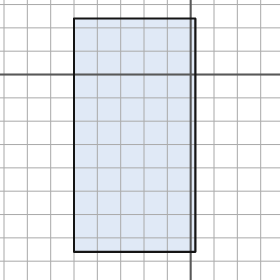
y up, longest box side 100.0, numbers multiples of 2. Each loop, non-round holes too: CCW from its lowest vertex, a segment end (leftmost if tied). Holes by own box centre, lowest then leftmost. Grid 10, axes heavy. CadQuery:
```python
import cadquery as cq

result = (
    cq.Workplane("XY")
    .moveTo(-50.0, -76.0)
    .lineTo(2.0, -76.0)
    .lineTo(2.0, 24.0)
    .lineTo(-50.0, 24.0)
    .close()
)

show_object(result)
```